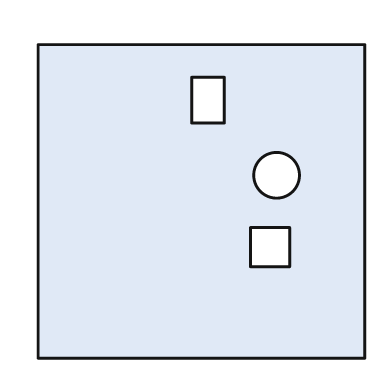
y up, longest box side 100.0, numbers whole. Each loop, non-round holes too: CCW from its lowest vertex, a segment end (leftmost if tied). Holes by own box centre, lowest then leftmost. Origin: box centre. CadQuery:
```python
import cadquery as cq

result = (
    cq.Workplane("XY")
    .moveTo(-50.0, -48.0)
    .lineTo(50.0, -48.0)
    .lineTo(50.0, 48.0)
    .lineTo(-50.0, 48.0)
    .close()
    .moveTo(15.0, -20.0)
    .lineTo(27.0, -20.0)
    .lineTo(27.0, -8.0)
    .lineTo(15.0, -8.0)
    .close()
    .moveTo(23.0, 8.0)
    .circle(7.0)
    .moveTo(-3.0, 24.0)
    .lineTo(7.0, 24.0)
    .lineTo(7.0, 38.0)
    .lineTo(-3.0, 38.0)
    .close()
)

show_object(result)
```